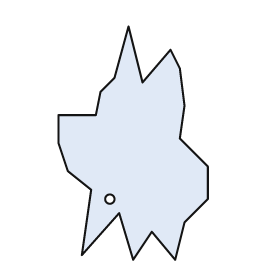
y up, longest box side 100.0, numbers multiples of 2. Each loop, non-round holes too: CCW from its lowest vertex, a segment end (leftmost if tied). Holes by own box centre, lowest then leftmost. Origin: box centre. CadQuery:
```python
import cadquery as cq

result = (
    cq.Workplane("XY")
    .moveTo(0.0, -50.0)
    .lineTo(8.0, -38.0)
    .lineTo(18.0, -50.0)
    .lineTo(22.0, -34.0)
    .lineTo(32.0, -24.0)
    .lineTo(32.0, -10.0)
    .lineTo(20.0, 2.0)
    .lineTo(22.0, 16.0)
    .lineTo(20.0, 32.0)
    .lineTo(16.0, 40.0)
    .lineTo(4.0, 26.0)
    .lineTo(-2.0, 50.0)
    .lineTo(-8.0, 28.0)
    .lineTo(-14.0, 22.0)
    .lineTo(-16.0, 12.0)
    .lineTo(-32.0, 12.0)
    .lineTo(-32.0, 0.0)
    .lineTo(-28.0, -12.0)
    .lineTo(-18.0, -20.0)
    .lineTo(-22.0, -48.0)
    .lineTo(-6.0, -30.0)
    .close()
    .moveTo(-10.0, -24.0)
    .circle(2.0)
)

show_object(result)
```